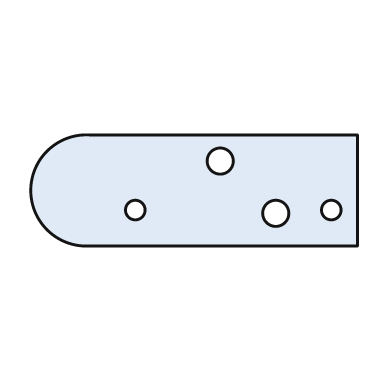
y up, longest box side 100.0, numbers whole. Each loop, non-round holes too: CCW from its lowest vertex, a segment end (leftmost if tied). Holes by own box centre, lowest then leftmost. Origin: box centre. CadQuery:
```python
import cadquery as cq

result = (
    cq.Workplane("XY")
    .moveTo(-32.0, -17.0)
    .lineTo(50.0, -17.0)
    .lineTo(50.0, 17.0)
    .lineTo(-32.0, 17.0)
    .threePointArc((-50.0, 0.0), (-32.0, -17.0))
    .close()
    .moveTo(25.0, -7.0)
    .circle(4.0)
    .moveTo(-18.0, -6.0)
    .circle(3.0)
    .moveTo(42.0, -6.0)
    .circle(3.0)
    .moveTo(8.0, 9.0)
    .circle(4.0)
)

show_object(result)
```